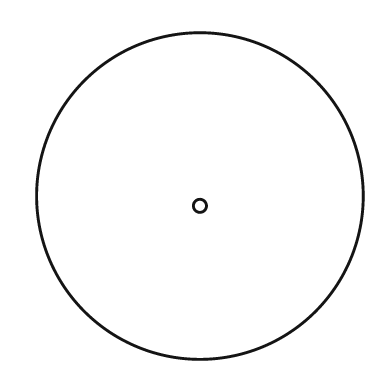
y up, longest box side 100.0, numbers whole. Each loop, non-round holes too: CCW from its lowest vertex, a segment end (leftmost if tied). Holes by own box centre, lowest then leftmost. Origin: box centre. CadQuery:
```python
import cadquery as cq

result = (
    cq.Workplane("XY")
    .moveTo(0.0, 0.0)
    .circle(50.0)
    .moveTo(0.0, -3.0)
    .circle(2.0)
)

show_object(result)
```